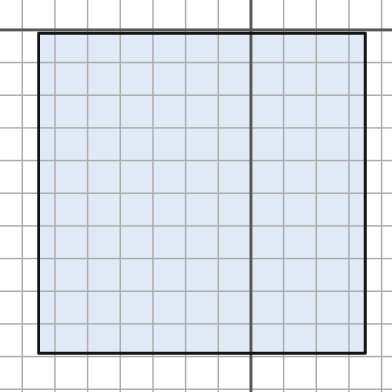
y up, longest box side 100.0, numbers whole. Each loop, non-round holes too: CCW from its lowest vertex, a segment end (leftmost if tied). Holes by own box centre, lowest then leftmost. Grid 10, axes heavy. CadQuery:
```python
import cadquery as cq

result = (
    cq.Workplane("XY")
    .moveTo(-65.0, -99.0)
    .lineTo(35.0, -99.0)
    .lineTo(35.0, -1.0)
    .lineTo(-65.0, -1.0)
    .close()
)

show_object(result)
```